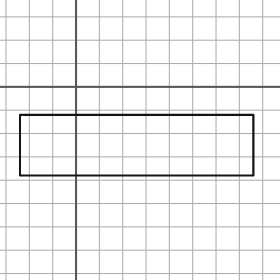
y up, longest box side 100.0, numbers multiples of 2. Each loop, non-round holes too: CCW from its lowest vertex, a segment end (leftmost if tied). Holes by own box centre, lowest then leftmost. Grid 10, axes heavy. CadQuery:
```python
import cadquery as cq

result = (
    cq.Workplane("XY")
    .moveTo(-24.0, -38.0)
    .lineTo(76.0, -38.0)
    .lineTo(76.0, -12.0)
    .lineTo(-24.0, -12.0)
    .close()
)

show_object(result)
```